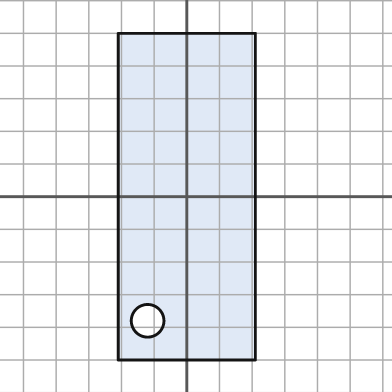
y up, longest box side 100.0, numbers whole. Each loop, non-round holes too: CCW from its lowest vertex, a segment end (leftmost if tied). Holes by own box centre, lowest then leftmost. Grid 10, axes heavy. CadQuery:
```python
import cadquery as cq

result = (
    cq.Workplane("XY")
    .moveTo(-21.0, -50.0)
    .lineTo(21.0, -50.0)
    .lineTo(21.0, 50.0)
    .lineTo(-21.0, 50.0)
    .close()
    .moveTo(-12.0, -38.0)
    .circle(5.0)
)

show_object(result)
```